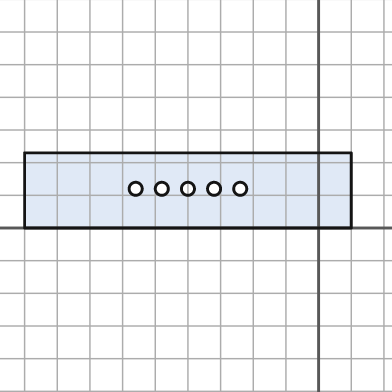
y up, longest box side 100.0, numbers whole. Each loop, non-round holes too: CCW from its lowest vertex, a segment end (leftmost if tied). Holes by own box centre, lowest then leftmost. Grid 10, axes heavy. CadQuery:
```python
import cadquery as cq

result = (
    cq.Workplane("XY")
    .moveTo(-90.0, 0.0)
    .lineTo(10.0, 0.0)
    .lineTo(10.0, 23.0)
    .lineTo(-90.0, 23.0)
    .close()
    .moveTo(-56.0, 12.0)
    .circle(2.0)
    .moveTo(-48.0, 12.0)
    .circle(2.0)
    .moveTo(-40.0, 12.0)
    .circle(2.0)
    .moveTo(-32.0, 12.0)
    .circle(2.0)
    .moveTo(-24.0, 12.0)
    .circle(2.0)
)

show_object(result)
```